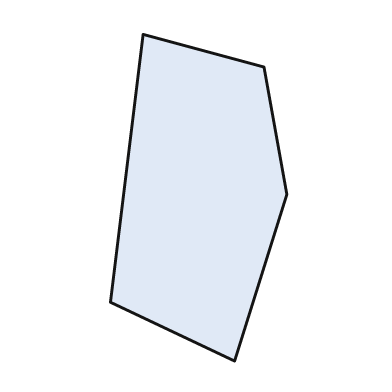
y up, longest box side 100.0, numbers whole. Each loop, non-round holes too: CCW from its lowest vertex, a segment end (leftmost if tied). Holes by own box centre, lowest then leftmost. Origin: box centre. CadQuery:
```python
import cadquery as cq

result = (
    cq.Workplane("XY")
    .moveTo(11.0, -50.0)
    .lineTo(27.0, 1.0)
    .lineTo(20.0, 40.0)
    .lineTo(-17.0, 50.0)
    .lineTo(-27.0, -32.0)
    .close()
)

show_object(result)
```